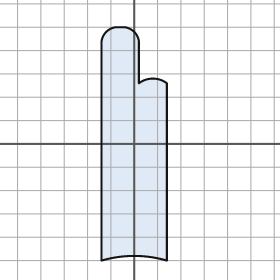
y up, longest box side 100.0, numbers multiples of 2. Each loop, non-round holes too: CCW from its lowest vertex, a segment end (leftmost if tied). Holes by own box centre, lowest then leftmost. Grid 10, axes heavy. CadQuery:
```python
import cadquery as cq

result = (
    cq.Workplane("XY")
    .moveTo(-14.0, -50.0)
    .threePointArc((0.0, -48.0), (14.0, -50.0))
    .lineTo(14.0, 26.0)
    .threePointArc((8.0, 28.0), (2.0, 26.0))
    .lineTo(2.0, 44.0)
    .threePointArc((0.0, 48.0), (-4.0, 50.0))
    .lineTo(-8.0, 50.0)
    .threePointArc((-12.0, 48.0), (-14.0, 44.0))
    .close()
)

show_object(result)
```